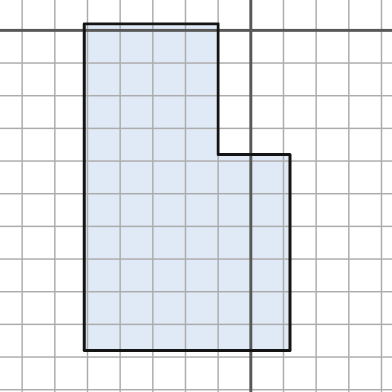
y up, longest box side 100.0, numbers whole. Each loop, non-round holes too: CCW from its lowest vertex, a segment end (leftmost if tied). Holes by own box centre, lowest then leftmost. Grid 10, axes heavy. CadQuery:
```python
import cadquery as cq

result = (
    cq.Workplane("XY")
    .moveTo(-51.0, -98.0)
    .lineTo(12.0, -98.0)
    .lineTo(12.0, -38.0)
    .lineTo(-10.0, -38.0)
    .lineTo(-10.0, 2.0)
    .lineTo(-51.0, 2.0)
    .close()
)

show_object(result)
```